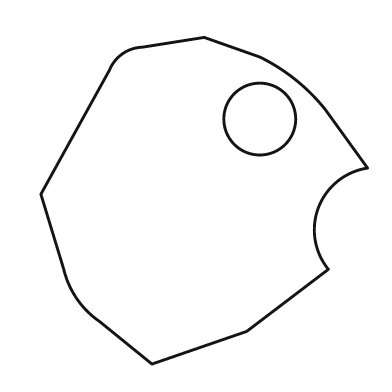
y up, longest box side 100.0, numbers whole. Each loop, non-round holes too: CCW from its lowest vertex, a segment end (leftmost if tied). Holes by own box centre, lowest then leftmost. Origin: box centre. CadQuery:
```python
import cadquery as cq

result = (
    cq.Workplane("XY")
    .moveTo(-16.0, -50.0)
    .lineTo(13.0, -40.0)
    .lineTo(38.0, -21.0)
    .threePointArc((35.0, -2.0), (50.0, 10.0))
    .lineTo(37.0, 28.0)
    .threePointArc((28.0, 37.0), (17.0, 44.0))
    .lineTo(0.0, 50.0)
    .lineTo(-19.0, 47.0)
    .threePointArc((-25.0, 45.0), (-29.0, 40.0))
    .lineTo(-50.0, 2.0)
    .lineTo(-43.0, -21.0)
    .threePointArc((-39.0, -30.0), (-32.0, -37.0))
    .close()
    .moveTo(17.0, 25.0)
    .circle(11.0)
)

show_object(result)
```